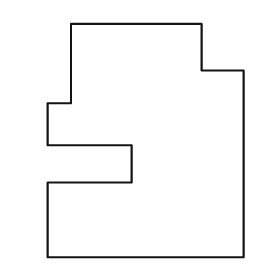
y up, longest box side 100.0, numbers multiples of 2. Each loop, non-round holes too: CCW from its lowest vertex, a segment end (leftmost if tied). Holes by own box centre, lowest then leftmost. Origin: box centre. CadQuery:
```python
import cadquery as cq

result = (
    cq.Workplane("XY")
    .moveTo(-42.0, -50.0)
    .lineTo(42.0, -50.0)
    .lineTo(42.0, 30.0)
    .lineTo(24.0, 30.0)
    .lineTo(24.0, 50.0)
    .lineTo(-32.0, 50.0)
    .lineTo(-32.0, 16.0)
    .lineTo(-42.0, 16.0)
    .lineTo(-42.0, -2.0)
    .lineTo(-6.0, -2.0)
    .lineTo(-6.0, -18.0)
    .lineTo(-42.0, -18.0)
    .close()
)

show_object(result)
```